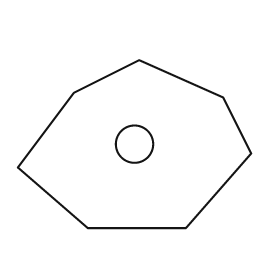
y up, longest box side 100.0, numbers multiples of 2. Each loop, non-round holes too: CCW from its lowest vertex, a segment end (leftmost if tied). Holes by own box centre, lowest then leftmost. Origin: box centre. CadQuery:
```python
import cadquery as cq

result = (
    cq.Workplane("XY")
    .moveTo(-20.0, -36.0)
    .lineTo(22.0, -36.0)
    .lineTo(50.0, -4.0)
    .lineTo(38.0, 20.0)
    .lineTo(2.0, 36.0)
    .lineTo(-26.0, 22.0)
    .lineTo(-50.0, -10.0)
    .close()
    .moveTo(0.0, 0.0)
    .circle(8.0)
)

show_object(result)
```